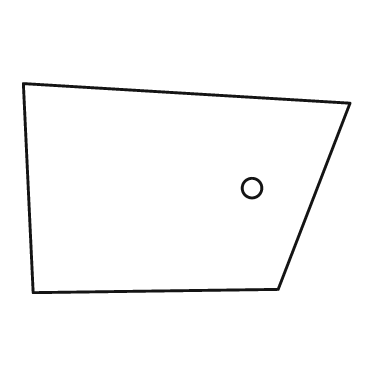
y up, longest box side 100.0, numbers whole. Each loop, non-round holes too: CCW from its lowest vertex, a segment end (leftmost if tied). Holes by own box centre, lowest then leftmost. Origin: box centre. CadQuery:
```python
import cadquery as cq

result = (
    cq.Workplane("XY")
    .moveTo(-47.0, -32.0)
    .lineTo(28.0, -31.0)
    .lineTo(50.0, 26.0)
    .lineTo(-50.0, 32.0)
    .close()
    .moveTo(20.0, 0.0)
    .circle(3.0)
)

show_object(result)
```